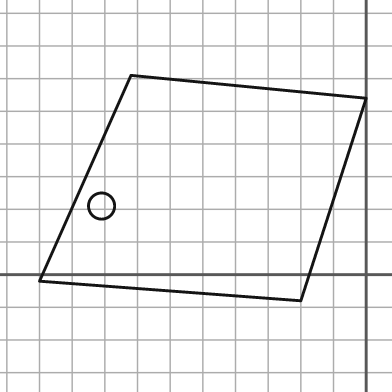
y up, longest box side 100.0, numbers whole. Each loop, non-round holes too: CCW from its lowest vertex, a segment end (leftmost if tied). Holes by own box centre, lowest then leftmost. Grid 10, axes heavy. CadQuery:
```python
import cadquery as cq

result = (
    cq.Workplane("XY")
    .moveTo(-20.0, -8.0)
    .lineTo(0.0, 54.0)
    .lineTo(-72.0, 61.0)
    .lineTo(-100.0, -2.0)
    .close()
    .moveTo(-81.0, 21.0)
    .circle(4.0)
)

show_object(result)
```